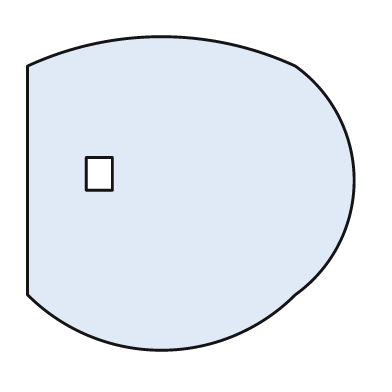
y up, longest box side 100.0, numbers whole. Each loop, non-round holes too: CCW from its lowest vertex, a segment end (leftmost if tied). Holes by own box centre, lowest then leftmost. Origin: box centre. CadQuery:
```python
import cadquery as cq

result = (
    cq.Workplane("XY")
    .moveTo(-50.0, -31.0)
    .threePointArc((-9.0, -48.0), (32.0, -31.0))
    .threePointArc((50.0, 4.0), (32.0, 39.0))
    .threePointArc((-9.0, 48.0), (-50.0, 39.0))
    .close()
    .moveTo(-32.0, 1.0)
    .lineTo(-24.0, 1.0)
    .lineTo(-24.0, 11.0)
    .lineTo(-32.0, 11.0)
    .close()
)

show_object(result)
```